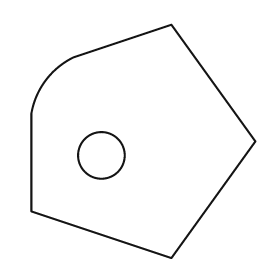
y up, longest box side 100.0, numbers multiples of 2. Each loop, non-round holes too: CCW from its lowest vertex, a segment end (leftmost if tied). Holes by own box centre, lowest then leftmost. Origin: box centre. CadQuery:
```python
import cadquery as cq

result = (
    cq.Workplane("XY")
    .moveTo(12.0, -50.0)
    .lineTo(48.0, 0.0)
    .lineTo(12.0, 50.0)
    .lineTo(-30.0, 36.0)
    .threePointArc((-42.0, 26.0), (-48.0, 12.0))
    .lineTo(-48.0, -30.0)
    .close()
    .moveTo(-18.0, -6.0)
    .circle(10.0)
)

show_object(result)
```